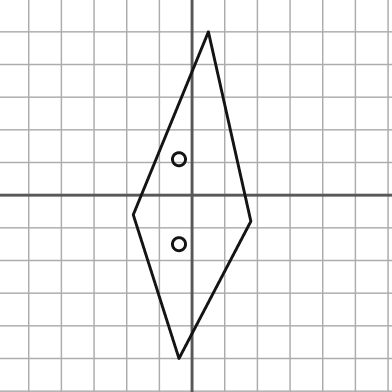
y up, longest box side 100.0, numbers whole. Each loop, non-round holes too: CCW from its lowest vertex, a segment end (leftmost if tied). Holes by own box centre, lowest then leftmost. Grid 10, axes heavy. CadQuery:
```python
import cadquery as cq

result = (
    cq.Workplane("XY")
    .moveTo(-4.0, -50.0)
    .lineTo(18.0, -8.0)
    .lineTo(5.0, 50.0)
    .lineTo(-18.0, -6.0)
    .close()
    .moveTo(-4.0, -15.0)
    .circle(2.0)
    .moveTo(-4.0, 11.0)
    .circle(2.0)
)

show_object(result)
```